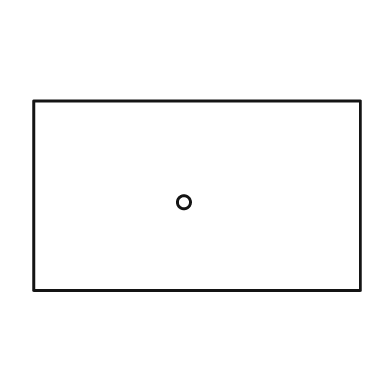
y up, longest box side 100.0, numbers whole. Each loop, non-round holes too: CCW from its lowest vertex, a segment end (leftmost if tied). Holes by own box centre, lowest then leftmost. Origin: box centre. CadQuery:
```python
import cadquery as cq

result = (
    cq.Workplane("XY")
    .moveTo(-50.0, -29.0)
    .lineTo(50.0, -29.0)
    .lineTo(50.0, 29.0)
    .lineTo(-50.0, 29.0)
    .close()
    .moveTo(-4.0, -2.0)
    .circle(2.0)
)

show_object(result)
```